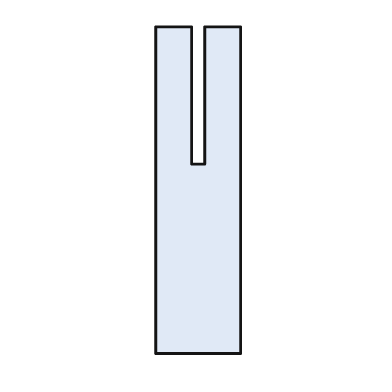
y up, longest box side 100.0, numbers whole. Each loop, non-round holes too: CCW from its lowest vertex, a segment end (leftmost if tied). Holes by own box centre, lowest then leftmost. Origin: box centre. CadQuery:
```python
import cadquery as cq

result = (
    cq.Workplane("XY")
    .moveTo(-13.0, -50.0)
    .lineTo(13.0, -50.0)
    .lineTo(13.0, 50.0)
    .lineTo(2.0, 50.0)
    .lineTo(2.0, 8.0)
    .lineTo(-2.0, 8.0)
    .lineTo(-2.0, 50.0)
    .lineTo(-13.0, 50.0)
    .close()
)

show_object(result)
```